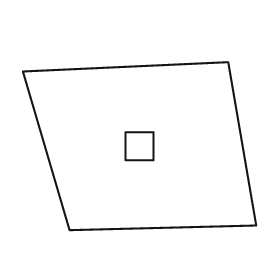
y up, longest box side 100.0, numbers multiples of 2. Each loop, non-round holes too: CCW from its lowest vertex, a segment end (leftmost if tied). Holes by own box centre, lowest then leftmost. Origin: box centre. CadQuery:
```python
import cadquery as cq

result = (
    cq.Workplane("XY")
    .moveTo(-30.0, -36.0)
    .lineTo(50.0, -34.0)
    .lineTo(38.0, 36.0)
    .lineTo(-50.0, 32.0)
    .close()
    .moveTo(-6.0, -6.0)
    .lineTo(6.0, -6.0)
    .lineTo(6.0, 6.0)
    .lineTo(-6.0, 6.0)
    .close()
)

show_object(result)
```